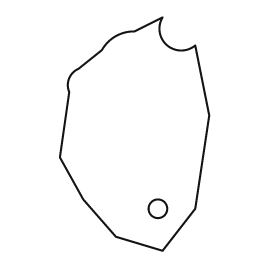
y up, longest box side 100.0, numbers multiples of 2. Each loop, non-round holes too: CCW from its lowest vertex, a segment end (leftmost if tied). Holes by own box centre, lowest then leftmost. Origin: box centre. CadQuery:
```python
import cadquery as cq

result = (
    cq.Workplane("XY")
    .moveTo(12.0, -50.0)
    .lineTo(26.0, -32.0)
    .lineTo(32.0, 8.0)
    .lineTo(26.0, 38.0)
    .threePointArc((14.0, 38.0), (12.0, 50.0))
    .lineTo(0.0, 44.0)
    .threePointArc((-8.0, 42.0), (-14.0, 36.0))
    .lineTo(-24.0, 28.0)
    .threePointArc((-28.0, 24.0), (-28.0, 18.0))
    .lineTo(-32.0, -10.0)
    .lineTo(-22.0, -28.0)
    .lineTo(-8.0, -44.0)
    .close()
    .moveTo(10.0, -32.0)
    .circle(4.0)
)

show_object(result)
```